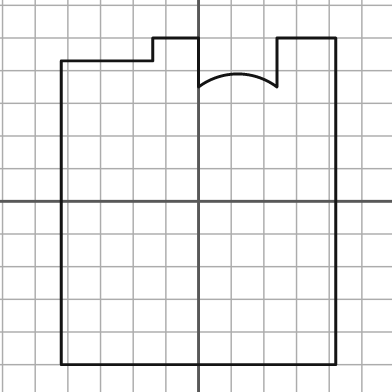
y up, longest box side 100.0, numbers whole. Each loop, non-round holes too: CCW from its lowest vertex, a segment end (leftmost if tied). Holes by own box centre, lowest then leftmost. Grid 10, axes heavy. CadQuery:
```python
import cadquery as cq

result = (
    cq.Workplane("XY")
    .moveTo(-42.0, -50.0)
    .lineTo(42.0, -50.0)
    .lineTo(42.0, 50.0)
    .lineTo(24.0, 50.0)
    .lineTo(24.0, 35.0)
    .threePointArc((12.0, 39.0), (0.0, 35.0))
    .lineTo(0.0, 50.0)
    .lineTo(-14.0, 50.0)
    .lineTo(-14.0, 43.0)
    .lineTo(-42.0, 43.0)
    .close()
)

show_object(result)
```